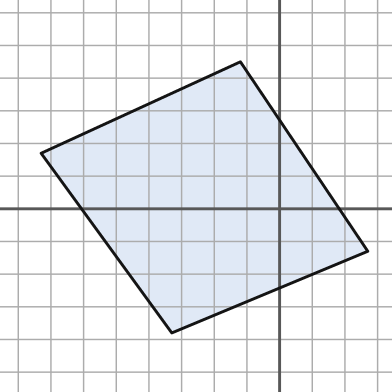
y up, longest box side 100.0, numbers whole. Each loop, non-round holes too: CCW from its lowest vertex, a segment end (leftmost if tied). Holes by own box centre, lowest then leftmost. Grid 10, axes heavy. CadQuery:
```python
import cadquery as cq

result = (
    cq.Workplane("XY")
    .moveTo(-33.0, -38.0)
    .lineTo(27.0, -13.0)
    .lineTo(-12.0, 45.0)
    .lineTo(-73.0, 17.0)
    .close()
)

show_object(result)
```